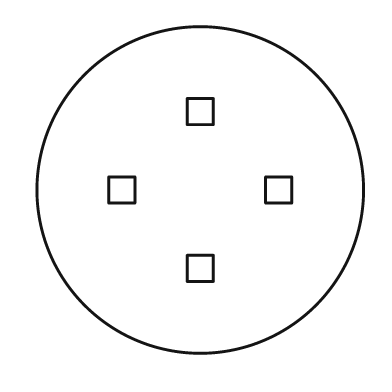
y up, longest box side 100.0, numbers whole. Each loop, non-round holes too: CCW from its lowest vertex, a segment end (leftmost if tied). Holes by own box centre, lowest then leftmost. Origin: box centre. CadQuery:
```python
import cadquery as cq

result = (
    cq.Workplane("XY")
    .moveTo(0.0, 0.0)
    .circle(50.0)
    .moveTo(-4.0, -28.0)
    .lineTo(4.0, -28.0)
    .lineTo(4.0, -20.0)
    .lineTo(-4.0, -20.0)
    .close()
    .moveTo(-28.0, -4.0)
    .lineTo(-20.0, -4.0)
    .lineTo(-20.0, 4.0)
    .lineTo(-28.0, 4.0)
    .close()
    .moveTo(20.0, -4.0)
    .lineTo(28.0, -4.0)
    .lineTo(28.0, 4.0)
    .lineTo(20.0, 4.0)
    .close()
    .moveTo(-4.0, 20.0)
    .lineTo(4.0, 20.0)
    .lineTo(4.0, 28.0)
    .lineTo(-4.0, 28.0)
    .close()
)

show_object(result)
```